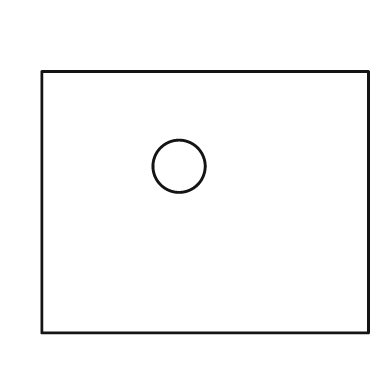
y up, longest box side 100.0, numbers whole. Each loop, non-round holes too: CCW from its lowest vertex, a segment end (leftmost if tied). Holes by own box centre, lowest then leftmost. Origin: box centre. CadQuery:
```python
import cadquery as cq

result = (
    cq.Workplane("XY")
    .moveTo(-50.0, -40.0)
    .lineTo(50.0, -40.0)
    .lineTo(50.0, 40.0)
    .lineTo(-50.0, 40.0)
    .close()
    .moveTo(-8.0, 11.0)
    .circle(8.0)
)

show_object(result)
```